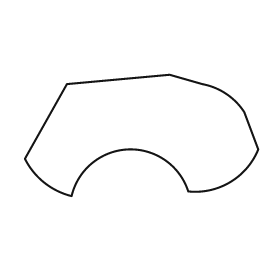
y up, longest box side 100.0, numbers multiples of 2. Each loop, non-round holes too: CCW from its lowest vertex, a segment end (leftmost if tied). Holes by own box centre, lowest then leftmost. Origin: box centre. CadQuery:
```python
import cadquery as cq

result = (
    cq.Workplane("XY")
    .moveTo(-30.0, -26.0)
    .threePointArc((-6.0, -6.0), (20.0, -24.0))
    .threePointArc((38.0, -20.0), (50.0, -6.0))
    .lineTo(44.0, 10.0)
    .threePointArc((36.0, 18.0), (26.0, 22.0))
    .lineTo(12.0, 26.0)
    .lineTo(-32.0, 22.0)
    .lineTo(-50.0, -10.0)
    .threePointArc((-42.0, -20.0), (-30.0, -26.0))
    .close()
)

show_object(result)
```